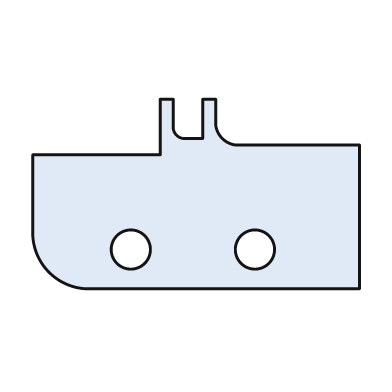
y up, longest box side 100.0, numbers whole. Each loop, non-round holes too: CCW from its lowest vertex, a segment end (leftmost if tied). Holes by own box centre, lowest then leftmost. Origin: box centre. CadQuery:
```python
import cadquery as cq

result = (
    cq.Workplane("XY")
    .moveTo(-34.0, -29.0)
    .lineTo(50.0, -29.0)
    .lineTo(50.0, 15.0)
    .lineTo(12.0, 15.0)
    .threePointArc((8.0, 17.0), (6.0, 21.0))
    .lineTo(6.0, 29.0)
    .lineTo(2.0, 29.0)
    .lineTo(2.0, 17.0)
    .lineTo(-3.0, 17.0)
    .threePointArc((-6.0, 18.0), (-7.0, 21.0))
    .lineTo(-7.0, 29.0)
    .lineTo(-11.0, 29.0)
    .lineTo(-11.0, 12.0)
    .lineTo(-50.0, 12.0)
    .lineTo(-50.0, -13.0)
    .threePointArc((-45.0, -24.0), (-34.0, -29.0))
    .close()
    .moveTo(-20.0, -17.0)
    .circle(6.0)
    .moveTo(18.0, -17.0)
    .circle(6.0)
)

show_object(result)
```